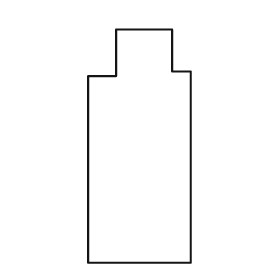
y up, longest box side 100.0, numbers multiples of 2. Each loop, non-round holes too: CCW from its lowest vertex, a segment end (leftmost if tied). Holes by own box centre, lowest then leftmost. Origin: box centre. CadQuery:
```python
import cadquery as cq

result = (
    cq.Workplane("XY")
    .moveTo(-22.0, -50.0)
    .lineTo(22.0, -50.0)
    .lineTo(22.0, 32.0)
    .lineTo(14.0, 32.0)
    .lineTo(14.0, 50.0)
    .lineTo(-10.0, 50.0)
    .lineTo(-10.0, 30.0)
    .lineTo(-22.0, 30.0)
    .close()
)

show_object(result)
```